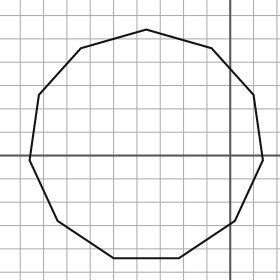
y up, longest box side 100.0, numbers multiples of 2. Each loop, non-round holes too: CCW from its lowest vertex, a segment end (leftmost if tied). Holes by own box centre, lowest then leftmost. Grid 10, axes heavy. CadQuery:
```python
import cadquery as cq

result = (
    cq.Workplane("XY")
    .moveTo(-50.0, -44.0)
    .lineTo(-22.0, -44.0)
    .lineTo(2.0, -28.0)
    .lineTo(14.0, -2.0)
    .lineTo(10.0, 26.0)
    .lineTo(-8.0, 46.0)
    .lineTo(-36.0, 54.0)
    .lineTo(-64.0, 46.0)
    .lineTo(-82.0, 26.0)
    .lineTo(-86.0, -2.0)
    .lineTo(-74.0, -28.0)
    .close()
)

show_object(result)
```